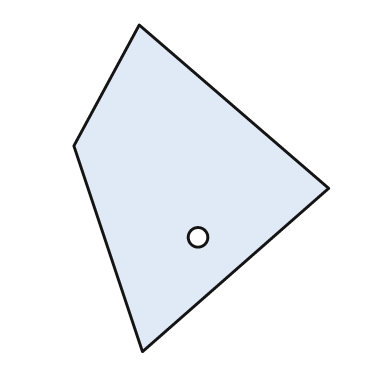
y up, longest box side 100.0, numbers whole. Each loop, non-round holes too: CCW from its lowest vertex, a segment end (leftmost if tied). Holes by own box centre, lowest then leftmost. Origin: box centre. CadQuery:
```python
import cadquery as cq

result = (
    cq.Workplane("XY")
    .moveTo(-18.0, -50.0)
    .lineTo(39.0, 0.0)
    .lineTo(-19.0, 50.0)
    .lineTo(-39.0, 13.0)
    .close()
    .moveTo(-1.0, -15.0)
    .circle(3.0)
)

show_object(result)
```